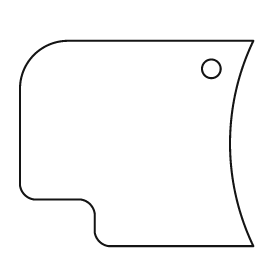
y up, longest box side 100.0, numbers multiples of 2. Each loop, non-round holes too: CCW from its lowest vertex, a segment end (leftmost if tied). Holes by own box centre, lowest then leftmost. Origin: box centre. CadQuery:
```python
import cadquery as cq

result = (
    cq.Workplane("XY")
    .moveTo(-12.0, -44.0)
    .lineTo(50.0, -44.0)
    .threePointArc((40.0, 0.0), (50.0, 44.0))
    .lineTo(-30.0, 44.0)
    .threePointArc((-44.0, 38.0), (-50.0, 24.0))
    .lineTo(-50.0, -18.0)
    .threePointArc((-48.0, -22.0), (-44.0, -24.0))
    .lineTo(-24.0, -24.0)
    .threePointArc((-20.0, -26.0), (-18.0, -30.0))
    .lineTo(-18.0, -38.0)
    .threePointArc((-16.0, -42.0), (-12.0, -44.0))
    .close()
    .moveTo(32.0, 32.0)
    .circle(4.0)
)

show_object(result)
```